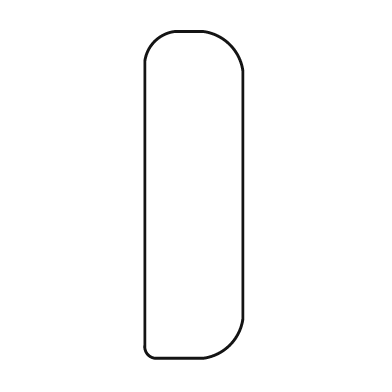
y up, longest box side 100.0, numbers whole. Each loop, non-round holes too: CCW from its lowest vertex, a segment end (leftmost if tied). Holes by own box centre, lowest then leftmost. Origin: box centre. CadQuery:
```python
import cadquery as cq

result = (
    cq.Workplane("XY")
    .moveTo(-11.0, -50.0)
    .lineTo(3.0, -50.0)
    .threePointArc((11.0, -46.0), (15.0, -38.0))
    .lineTo(15.0, 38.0)
    .threePointArc((11.0, 46.0), (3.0, 50.0))
    .lineTo(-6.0, 50.0)
    .threePointArc((-12.0, 47.0), (-15.0, 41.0))
    .lineTo(-15.0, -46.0)
    .threePointArc((-14.0, -49.0), (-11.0, -50.0))
    .close()
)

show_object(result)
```